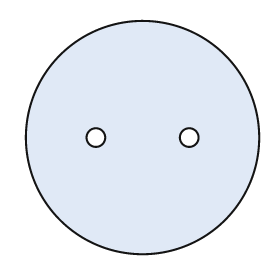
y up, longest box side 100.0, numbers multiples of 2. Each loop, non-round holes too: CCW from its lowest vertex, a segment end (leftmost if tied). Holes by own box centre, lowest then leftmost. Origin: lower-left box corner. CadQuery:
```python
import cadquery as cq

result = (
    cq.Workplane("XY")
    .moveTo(50.0, 50.0)
    .circle(50.0)
    .moveTo(30.0, 50.0)
    .circle(4.0)
    .moveTo(70.0, 50.0)
    .circle(4.0)
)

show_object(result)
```